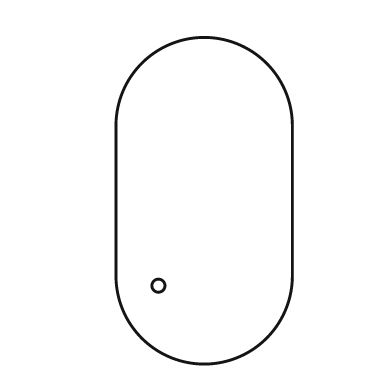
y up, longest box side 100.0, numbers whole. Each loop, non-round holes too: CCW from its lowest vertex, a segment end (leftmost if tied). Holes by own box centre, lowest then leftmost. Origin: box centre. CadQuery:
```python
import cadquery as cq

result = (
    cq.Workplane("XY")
    .moveTo(-27.0, -23.0)
    .threePointArc((0.0, -50.0), (27.0, -23.0))
    .lineTo(27.0, 23.0)
    .threePointArc((0.0, 50.0), (-27.0, 23.0))
    .close()
    .moveTo(-14.0, -26.0)
    .circle(2.0)
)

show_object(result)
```